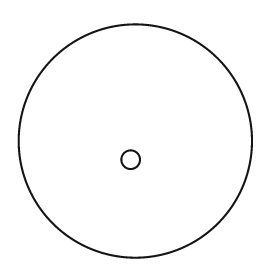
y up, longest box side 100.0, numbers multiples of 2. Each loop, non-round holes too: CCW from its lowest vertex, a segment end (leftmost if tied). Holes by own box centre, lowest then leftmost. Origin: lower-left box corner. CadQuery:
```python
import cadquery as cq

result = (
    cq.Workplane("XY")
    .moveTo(50.0, 50.0)
    .circle(50.0)
    .moveTo(48.0, 42.0)
    .circle(4.0)
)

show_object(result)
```